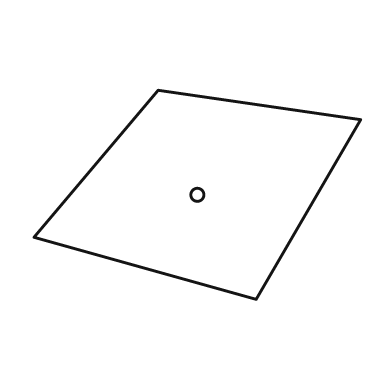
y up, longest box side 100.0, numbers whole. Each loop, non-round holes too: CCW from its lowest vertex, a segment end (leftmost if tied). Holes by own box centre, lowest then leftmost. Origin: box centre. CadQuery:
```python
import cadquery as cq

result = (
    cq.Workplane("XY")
    .moveTo(18.0, -32.0)
    .lineTo(50.0, 23.0)
    .lineTo(-12.0, 32.0)
    .lineTo(-50.0, -13.0)
    .close()
    .moveTo(0.0, 0.0)
    .circle(2.0)
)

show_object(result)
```